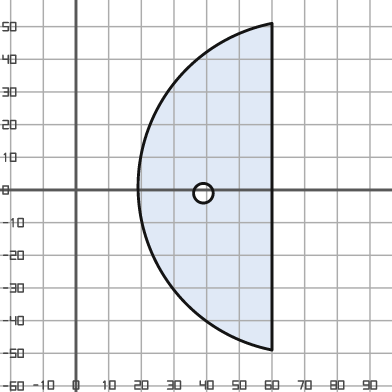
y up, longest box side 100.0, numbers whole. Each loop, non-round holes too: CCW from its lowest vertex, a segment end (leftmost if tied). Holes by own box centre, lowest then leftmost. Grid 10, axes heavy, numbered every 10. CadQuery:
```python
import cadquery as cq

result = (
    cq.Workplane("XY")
    .moveTo(60.0, -49.0)
    .lineTo(60.0, 51.0)
    .threePointArc((19.0, 1.0), (60.0, -49.0))
    .close()
    .moveTo(39.0, -1.0)
    .circle(3.0)
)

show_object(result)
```